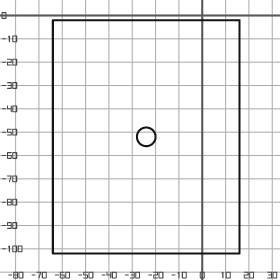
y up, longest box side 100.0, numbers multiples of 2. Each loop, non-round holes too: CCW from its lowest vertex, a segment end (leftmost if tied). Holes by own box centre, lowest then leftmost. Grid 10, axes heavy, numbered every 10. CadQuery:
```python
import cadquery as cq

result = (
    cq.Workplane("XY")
    .moveTo(-64.0, -102.0)
    .lineTo(16.0, -102.0)
    .lineTo(16.0, -2.0)
    .lineTo(-64.0, -2.0)
    .close()
    .moveTo(-24.0, -52.0)
    .circle(4.0)
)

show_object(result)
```